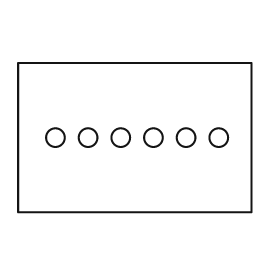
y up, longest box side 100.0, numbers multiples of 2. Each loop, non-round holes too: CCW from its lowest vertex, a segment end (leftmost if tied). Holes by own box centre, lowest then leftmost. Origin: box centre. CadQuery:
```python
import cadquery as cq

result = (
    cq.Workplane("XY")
    .moveTo(-50.0, -32.0)
    .lineTo(50.0, -32.0)
    .lineTo(50.0, 32.0)
    .lineTo(-50.0, 32.0)
    .close()
    .moveTo(-34.0, 0.0)
    .circle(4.0)
    .moveTo(-20.0, 0.0)
    .circle(4.0)
    .moveTo(-6.0, 0.0)
    .circle(4.0)
    .moveTo(8.0, 0.0)
    .circle(4.0)
    .moveTo(22.0, 0.0)
    .circle(4.0)
    .moveTo(36.0, 0.0)
    .circle(4.0)
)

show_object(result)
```